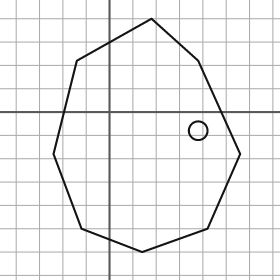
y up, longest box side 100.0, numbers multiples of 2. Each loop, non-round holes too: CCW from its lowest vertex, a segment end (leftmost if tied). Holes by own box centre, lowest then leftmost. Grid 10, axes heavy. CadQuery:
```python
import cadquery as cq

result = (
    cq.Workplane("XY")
    .moveTo(14.0, -60.0)
    .lineTo(42.0, -50.0)
    .lineTo(56.0, -18.0)
    .lineTo(38.0, 22.0)
    .lineTo(18.0, 40.0)
    .lineTo(-14.0, 22.0)
    .lineTo(-24.0, -18.0)
    .lineTo(-12.0, -50.0)
    .close()
    .moveTo(38.0, -8.0)
    .circle(4.0)
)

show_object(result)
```